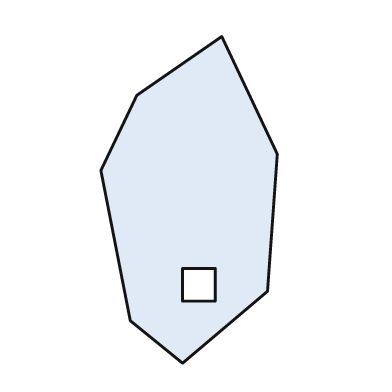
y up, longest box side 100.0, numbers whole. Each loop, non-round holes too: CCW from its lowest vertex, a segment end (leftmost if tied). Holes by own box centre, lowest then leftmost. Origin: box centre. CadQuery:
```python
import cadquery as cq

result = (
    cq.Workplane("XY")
    .moveTo(-2.0, -50.0)
    .lineTo(24.0, -28.0)
    .lineTo(27.0, 14.0)
    .lineTo(10.0, 50.0)
    .lineTo(-16.0, 32.0)
    .lineTo(-27.0, 9.0)
    .lineTo(-18.0, -37.0)
    .close()
    .moveTo(-2.0, -31.0)
    .lineTo(8.0, -31.0)
    .lineTo(8.0, -21.0)
    .lineTo(-2.0, -21.0)
    .close()
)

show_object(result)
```